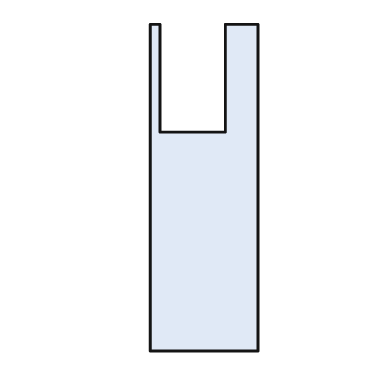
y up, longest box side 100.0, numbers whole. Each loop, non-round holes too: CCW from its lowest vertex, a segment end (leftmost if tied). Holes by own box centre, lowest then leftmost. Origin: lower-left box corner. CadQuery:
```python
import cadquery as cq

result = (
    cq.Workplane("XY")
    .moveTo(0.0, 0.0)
    .lineTo(33.0, 0.0)
    .lineTo(33.0, 100.0)
    .lineTo(23.0, 100.0)
    .lineTo(23.0, 67.0)
    .lineTo(3.0, 67.0)
    .lineTo(3.0, 100.0)
    .lineTo(0.0, 100.0)
    .close()
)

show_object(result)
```